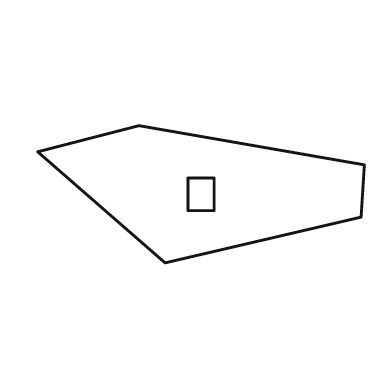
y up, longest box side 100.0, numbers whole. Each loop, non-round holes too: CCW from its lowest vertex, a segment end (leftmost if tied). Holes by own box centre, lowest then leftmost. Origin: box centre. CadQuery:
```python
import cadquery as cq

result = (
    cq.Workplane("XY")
    .moveTo(-11.0, -21.0)
    .lineTo(49.0, -7.0)
    .lineTo(50.0, 9.0)
    .lineTo(-19.0, 21.0)
    .lineTo(-50.0, 13.0)
    .close()
    .moveTo(-4.0, -5.0)
    .lineTo(4.0, -5.0)
    .lineTo(4.0, 5.0)
    .lineTo(-4.0, 5.0)
    .close()
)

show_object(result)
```